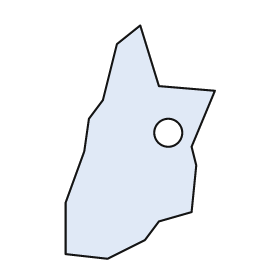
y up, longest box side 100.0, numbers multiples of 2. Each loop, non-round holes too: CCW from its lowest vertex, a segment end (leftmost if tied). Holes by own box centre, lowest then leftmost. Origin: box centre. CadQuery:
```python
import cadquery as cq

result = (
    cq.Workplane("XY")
    .moveTo(-14.0, -50.0)
    .lineTo(2.0, -42.0)
    .lineTo(8.0, -34.0)
    .lineTo(22.0, -30.0)
    .lineTo(24.0, -10.0)
    .lineTo(22.0, -2.0)
    .lineTo(32.0, 22.0)
    .lineTo(8.0, 24.0)
    .lineTo(0.0, 50.0)
    .lineTo(-10.0, 42.0)
    .lineTo(-16.0, 18.0)
    .lineTo(-22.0, 10.0)
    .lineTo(-24.0, -4.0)
    .lineTo(-32.0, -26.0)
    .lineTo(-32.0, -48.0)
    .close()
    .moveTo(12.0, 4.0)
    .circle(6.0)
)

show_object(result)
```